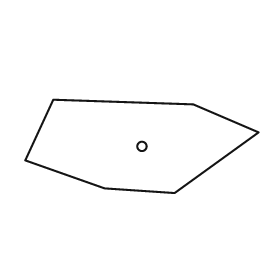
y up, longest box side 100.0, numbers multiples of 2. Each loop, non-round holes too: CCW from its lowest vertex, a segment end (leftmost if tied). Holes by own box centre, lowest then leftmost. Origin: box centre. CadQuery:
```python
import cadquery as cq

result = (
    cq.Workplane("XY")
    .moveTo(14.0, -20.0)
    .lineTo(50.0, 6.0)
    .lineTo(22.0, 18.0)
    .lineTo(-38.0, 20.0)
    .lineTo(-50.0, -6.0)
    .lineTo(-16.0, -18.0)
    .close()
    .moveTo(0.0, 0.0)
    .circle(2.0)
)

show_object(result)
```